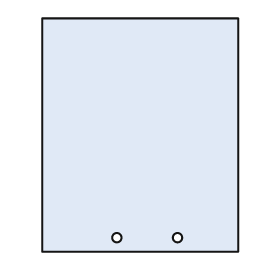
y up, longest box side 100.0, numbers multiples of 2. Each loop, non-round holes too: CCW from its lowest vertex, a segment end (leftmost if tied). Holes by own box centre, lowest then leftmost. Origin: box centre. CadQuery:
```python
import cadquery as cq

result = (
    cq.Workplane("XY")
    .moveTo(-42.0, -50.0)
    .lineTo(42.0, -50.0)
    .lineTo(42.0, 50.0)
    .lineTo(-42.0, 50.0)
    .close()
    .moveTo(-10.0, -44.0)
    .circle(2.0)
    .moveTo(16.0, -44.0)
    .circle(2.0)
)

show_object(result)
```